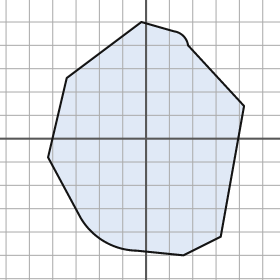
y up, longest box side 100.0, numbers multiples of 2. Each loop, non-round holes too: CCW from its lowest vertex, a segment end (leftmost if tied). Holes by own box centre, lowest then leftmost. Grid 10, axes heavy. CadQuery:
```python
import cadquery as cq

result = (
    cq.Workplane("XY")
    .moveTo(16.0, -50.0)
    .lineTo(32.0, -42.0)
    .lineTo(42.0, 14.0)
    .lineTo(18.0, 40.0)
    .threePointArc((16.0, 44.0), (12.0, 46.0))
    .lineTo(-2.0, 50.0)
    .lineTo(-34.0, 26.0)
    .lineTo(-42.0, -8.0)
    .lineTo(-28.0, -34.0)
    .threePointArc((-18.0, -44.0), (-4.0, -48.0))
    .close()
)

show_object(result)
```